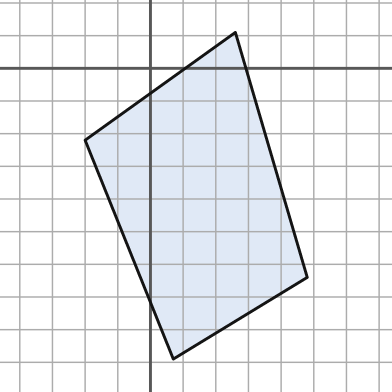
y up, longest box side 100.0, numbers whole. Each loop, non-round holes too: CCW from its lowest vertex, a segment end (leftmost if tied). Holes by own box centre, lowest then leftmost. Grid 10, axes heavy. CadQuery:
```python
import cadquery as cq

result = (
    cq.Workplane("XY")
    .moveTo(7.0, -89.0)
    .lineTo(48.0, -64.0)
    .lineTo(26.0, 11.0)
    .lineTo(-20.0, -22.0)
    .close()
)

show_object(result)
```